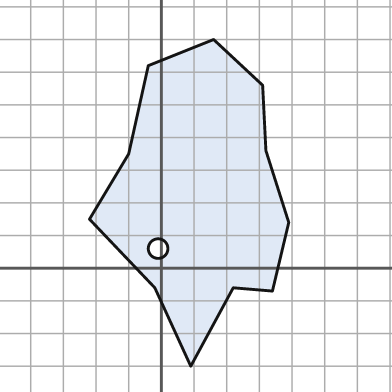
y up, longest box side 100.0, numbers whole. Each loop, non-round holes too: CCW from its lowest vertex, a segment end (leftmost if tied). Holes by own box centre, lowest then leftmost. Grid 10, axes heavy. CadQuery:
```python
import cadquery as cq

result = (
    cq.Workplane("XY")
    .moveTo(9.0, -30.0)
    .lineTo(22.0, -6.0)
    .lineTo(34.0, -7.0)
    .lineTo(39.0, 14.0)
    .lineTo(32.0, 36.0)
    .lineTo(31.0, 56.0)
    .lineTo(16.0, 70.0)
    .lineTo(-4.0, 62.0)
    .lineTo(-10.0, 35.0)
    .lineTo(-22.0, 15.0)
    .lineTo(-2.0, -6.0)
    .close()
    .moveTo(-1.0, 6.0)
    .circle(3.0)
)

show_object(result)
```